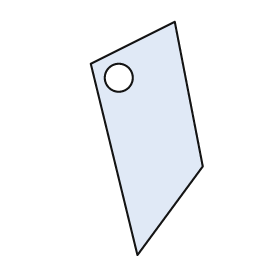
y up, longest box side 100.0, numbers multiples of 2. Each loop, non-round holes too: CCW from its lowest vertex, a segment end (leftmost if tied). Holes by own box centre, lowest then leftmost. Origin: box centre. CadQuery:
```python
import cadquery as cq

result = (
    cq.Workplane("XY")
    .moveTo(-4.0, -50.0)
    .lineTo(24.0, -12.0)
    .lineTo(12.0, 50.0)
    .lineTo(-24.0, 32.0)
    .close()
    .moveTo(-12.0, 26.0)
    .circle(6.0)
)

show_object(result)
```